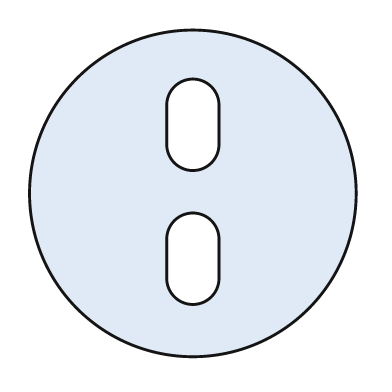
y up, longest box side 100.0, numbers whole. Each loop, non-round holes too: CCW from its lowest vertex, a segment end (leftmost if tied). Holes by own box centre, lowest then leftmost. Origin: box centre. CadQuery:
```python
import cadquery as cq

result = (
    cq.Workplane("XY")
    .moveTo(0.0, 0.0)
    .circle(50.0)
    .moveTo(-8.0, -26.0)
    .threePointArc((0.0, -34.0), (8.0, -26.0))
    .lineTo(8.0, -14.0)
    .threePointArc((0.0, -6.0), (-8.0, -14.0))
    .close()
    .moveTo(-8.0, 15.0)
    .threePointArc((0.0, 7.0), (8.0, 15.0))
    .lineTo(8.0, 27.0)
    .threePointArc((0.0, 35.0), (-8.0, 27.0))
    .close()
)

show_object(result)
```